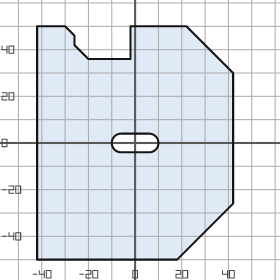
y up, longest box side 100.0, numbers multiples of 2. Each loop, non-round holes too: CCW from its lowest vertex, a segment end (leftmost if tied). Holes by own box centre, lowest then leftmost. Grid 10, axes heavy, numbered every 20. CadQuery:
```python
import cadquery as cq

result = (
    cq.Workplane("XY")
    .moveTo(-42.0, -50.0)
    .lineTo(18.0, -50.0)
    .lineTo(42.0, -26.0)
    .lineTo(42.0, 30.0)
    .lineTo(22.0, 50.0)
    .lineTo(-2.0, 50.0)
    .lineTo(-2.0, 36.0)
    .lineTo(-20.0, 36.0)
    .lineTo(-26.0, 42.0)
    .lineTo(-26.0, 46.0)
    .lineTo(-30.0, 50.0)
    .lineTo(-42.0, 50.0)
    .close()
    .moveTo(-6.0, -4.0)
    .lineTo(6.0, -4.0)
    .threePointArc((10.0, 0.0), (6.0, 4.0))
    .lineTo(-6.0, 4.0)
    .threePointArc((-10.0, 0.0), (-6.0, -4.0))
    .close()
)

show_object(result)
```